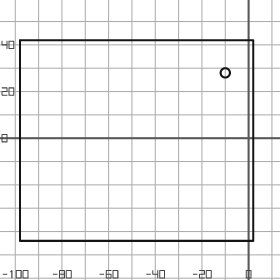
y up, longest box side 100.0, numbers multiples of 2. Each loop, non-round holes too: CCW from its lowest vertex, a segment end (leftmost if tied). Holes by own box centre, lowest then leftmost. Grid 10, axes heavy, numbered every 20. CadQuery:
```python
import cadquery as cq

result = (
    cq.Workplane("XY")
    .moveTo(-98.0, -44.0)
    .lineTo(2.0, -44.0)
    .lineTo(2.0, 42.0)
    .lineTo(-98.0, 42.0)
    .close()
    .moveTo(-10.0, 28.0)
    .circle(2.0)
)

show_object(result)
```